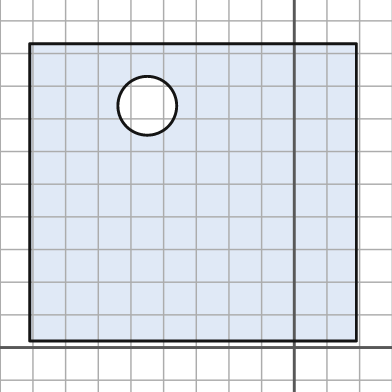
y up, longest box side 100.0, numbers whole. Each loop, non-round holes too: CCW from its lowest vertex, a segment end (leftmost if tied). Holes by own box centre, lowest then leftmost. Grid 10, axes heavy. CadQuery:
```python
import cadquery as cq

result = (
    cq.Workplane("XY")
    .moveTo(-81.0, 2.0)
    .lineTo(19.0, 2.0)
    .lineTo(19.0, 93.0)
    .lineTo(-81.0, 93.0)
    .close()
    .moveTo(-45.0, 74.0)
    .circle(9.0)
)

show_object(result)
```